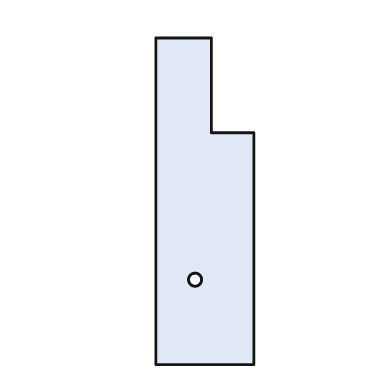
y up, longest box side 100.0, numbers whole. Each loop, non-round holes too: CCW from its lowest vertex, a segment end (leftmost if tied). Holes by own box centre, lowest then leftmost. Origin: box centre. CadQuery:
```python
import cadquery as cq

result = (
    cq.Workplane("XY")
    .moveTo(-15.0, -50.0)
    .lineTo(15.0, -50.0)
    .lineTo(15.0, 21.0)
    .lineTo(2.0, 21.0)
    .lineTo(2.0, 50.0)
    .lineTo(-15.0, 50.0)
    .close()
    .moveTo(-3.0, -24.0)
    .circle(2.0)
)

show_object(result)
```